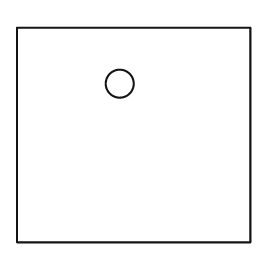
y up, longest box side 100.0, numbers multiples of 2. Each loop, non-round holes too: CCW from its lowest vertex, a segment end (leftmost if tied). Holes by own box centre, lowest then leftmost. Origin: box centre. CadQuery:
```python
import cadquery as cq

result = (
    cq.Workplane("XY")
    .moveTo(-50.0, -46.0)
    .lineTo(50.0, -46.0)
    .lineTo(50.0, 46.0)
    .lineTo(-50.0, 46.0)
    .close()
    .moveTo(-6.0, 22.0)
    .circle(6.0)
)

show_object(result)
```